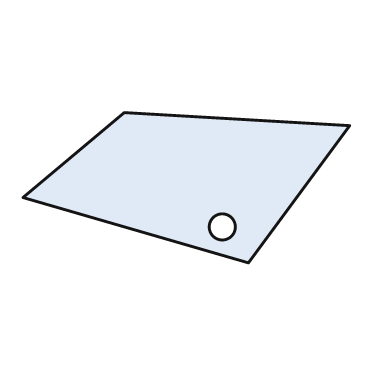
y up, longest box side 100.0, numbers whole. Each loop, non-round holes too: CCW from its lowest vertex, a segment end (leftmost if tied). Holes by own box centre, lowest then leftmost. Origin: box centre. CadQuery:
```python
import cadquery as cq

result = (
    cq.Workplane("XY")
    .moveTo(19.0, -23.0)
    .lineTo(50.0, 19.0)
    .lineTo(-19.0, 23.0)
    .lineTo(-50.0, -3.0)
    .close()
    .moveTo(11.0, -12.0)
    .circle(4.0)
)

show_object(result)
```